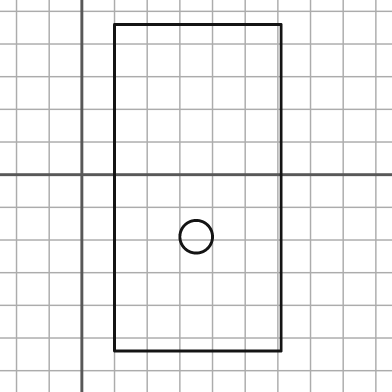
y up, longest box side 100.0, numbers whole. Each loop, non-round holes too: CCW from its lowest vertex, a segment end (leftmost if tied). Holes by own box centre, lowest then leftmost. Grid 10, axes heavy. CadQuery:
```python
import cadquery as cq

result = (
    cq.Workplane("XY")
    .moveTo(10.0, -54.0)
    .lineTo(61.0, -54.0)
    .lineTo(61.0, 46.0)
    .lineTo(10.0, 46.0)
    .close()
    .moveTo(35.0, -19.0)
    .circle(5.0)
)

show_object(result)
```